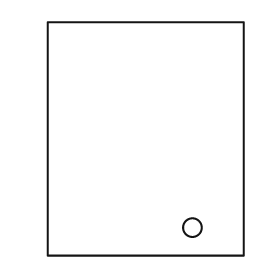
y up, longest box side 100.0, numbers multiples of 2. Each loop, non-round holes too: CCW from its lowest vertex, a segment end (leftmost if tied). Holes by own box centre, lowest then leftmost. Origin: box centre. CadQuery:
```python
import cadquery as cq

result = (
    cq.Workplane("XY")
    .moveTo(-42.0, -50.0)
    .lineTo(42.0, -50.0)
    .lineTo(42.0, 50.0)
    .lineTo(-42.0, 50.0)
    .close()
    .moveTo(20.0, -38.0)
    .circle(4.0)
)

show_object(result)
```